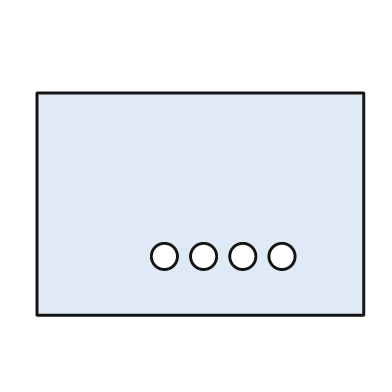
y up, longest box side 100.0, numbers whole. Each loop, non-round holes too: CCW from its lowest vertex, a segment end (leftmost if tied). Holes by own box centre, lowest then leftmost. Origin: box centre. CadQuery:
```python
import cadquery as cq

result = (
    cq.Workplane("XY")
    .moveTo(-50.0, -34.0)
    .lineTo(50.0, -34.0)
    .lineTo(50.0, 34.0)
    .lineTo(-50.0, 34.0)
    .close()
    .moveTo(-11.0, -16.0)
    .circle(4.0)
    .moveTo(1.0, -16.0)
    .circle(4.0)
    .moveTo(13.0, -16.0)
    .circle(4.0)
    .moveTo(25.0, -16.0)
    .circle(4.0)
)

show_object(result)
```